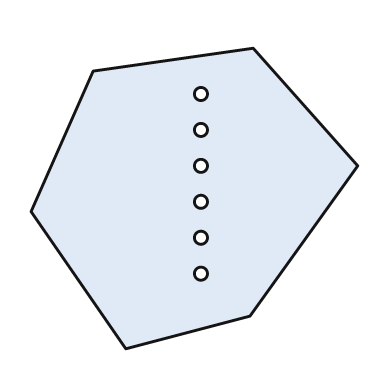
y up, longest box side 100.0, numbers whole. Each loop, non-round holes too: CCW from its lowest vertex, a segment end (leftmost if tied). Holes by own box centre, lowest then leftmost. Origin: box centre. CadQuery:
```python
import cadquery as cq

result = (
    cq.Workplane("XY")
    .moveTo(-21.0, -46.0)
    .lineTo(17.0, -36.0)
    .lineTo(50.0, 10.0)
    .lineTo(18.0, 46.0)
    .lineTo(-31.0, 39.0)
    .lineTo(-50.0, -4.0)
    .close()
    .moveTo(2.0, -23.0)
    .circle(2.0)
    .moveTo(2.0, -12.0)
    .circle(2.0)
    .moveTo(2.0, -1.0)
    .circle(2.0)
    .moveTo(2.0, 10.0)
    .circle(2.0)
    .moveTo(2.0, 21.0)
    .circle(2.0)
    .moveTo(2.0, 32.0)
    .circle(2.0)
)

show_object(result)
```